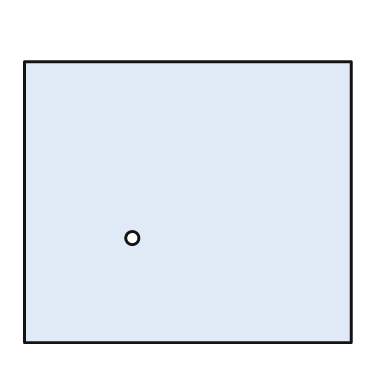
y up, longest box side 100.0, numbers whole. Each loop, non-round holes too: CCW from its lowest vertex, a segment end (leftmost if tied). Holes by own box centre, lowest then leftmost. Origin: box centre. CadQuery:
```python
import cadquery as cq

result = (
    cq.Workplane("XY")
    .moveTo(-50.0, -43.0)
    .lineTo(50.0, -43.0)
    .lineTo(50.0, 43.0)
    .lineTo(-50.0, 43.0)
    .close()
    .moveTo(-17.0, -11.0)
    .circle(2.0)
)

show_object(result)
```